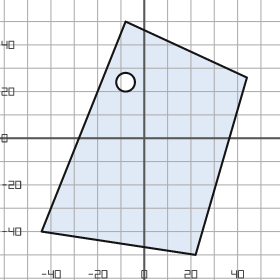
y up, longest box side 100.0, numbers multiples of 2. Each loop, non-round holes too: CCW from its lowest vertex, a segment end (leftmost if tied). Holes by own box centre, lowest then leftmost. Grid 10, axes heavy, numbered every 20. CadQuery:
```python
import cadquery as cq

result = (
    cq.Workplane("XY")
    .moveTo(22.0, -50.0)
    .lineTo(44.0, 26.0)
    .lineTo(-8.0, 50.0)
    .lineTo(-44.0, -40.0)
    .close()
    .moveTo(-8.0, 24.0)
    .circle(4.0)
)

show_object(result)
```